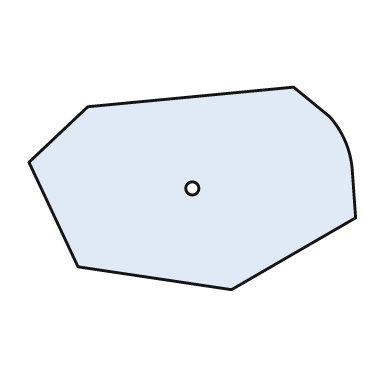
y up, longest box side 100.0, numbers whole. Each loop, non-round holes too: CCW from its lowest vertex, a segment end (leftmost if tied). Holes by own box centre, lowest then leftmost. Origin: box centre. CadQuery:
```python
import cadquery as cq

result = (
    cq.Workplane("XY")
    .moveTo(12.0, -31.0)
    .lineTo(50.0, -9.0)
    .lineTo(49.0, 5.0)
    .threePointArc((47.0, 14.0), (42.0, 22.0))
    .lineTo(31.0, 31.0)
    .lineTo(-32.0, 25.0)
    .lineTo(-50.0, 8.0)
    .lineTo(-35.0, -24.0)
    .close()
    .moveTo(0.0, 0.0)
    .circle(2.0)
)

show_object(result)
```